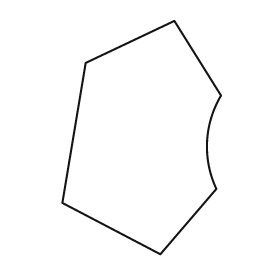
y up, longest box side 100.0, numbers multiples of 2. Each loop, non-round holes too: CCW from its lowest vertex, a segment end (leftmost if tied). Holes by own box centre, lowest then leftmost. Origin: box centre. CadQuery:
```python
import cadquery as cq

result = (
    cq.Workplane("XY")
    .moveTo(8.0, -50.0)
    .lineTo(32.0, -22.0)
    .threePointArc((28.0, -2.0), (34.0, 18.0))
    .lineTo(14.0, 50.0)
    .lineTo(-24.0, 32.0)
    .lineTo(-34.0, -28.0)
    .close()
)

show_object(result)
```